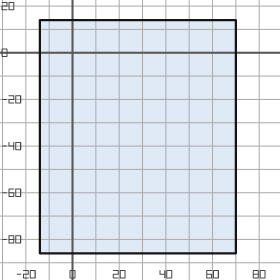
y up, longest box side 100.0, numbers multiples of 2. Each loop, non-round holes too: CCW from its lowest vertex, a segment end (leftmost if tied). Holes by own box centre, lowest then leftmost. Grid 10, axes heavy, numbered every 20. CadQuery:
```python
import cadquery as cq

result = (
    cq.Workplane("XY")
    .moveTo(-14.0, -86.0)
    .lineTo(70.0, -86.0)
    .lineTo(70.0, 14.0)
    .lineTo(-14.0, 14.0)
    .close()
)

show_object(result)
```